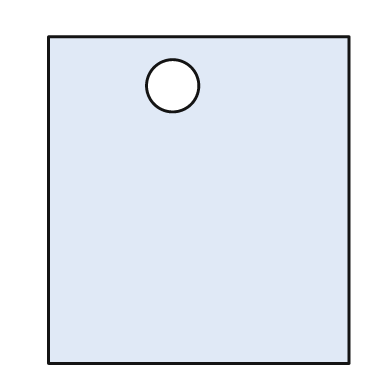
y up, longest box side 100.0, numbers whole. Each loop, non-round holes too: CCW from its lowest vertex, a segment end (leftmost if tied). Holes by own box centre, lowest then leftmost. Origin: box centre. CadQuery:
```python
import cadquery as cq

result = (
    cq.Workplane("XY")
    .moveTo(-46.0, -50.0)
    .lineTo(46.0, -50.0)
    .lineTo(46.0, 50.0)
    .lineTo(-46.0, 50.0)
    .close()
    .moveTo(-8.0, 35.0)
    .circle(8.0)
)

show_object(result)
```